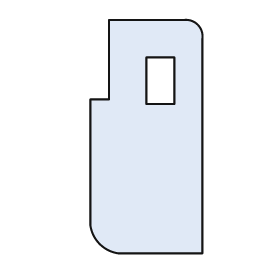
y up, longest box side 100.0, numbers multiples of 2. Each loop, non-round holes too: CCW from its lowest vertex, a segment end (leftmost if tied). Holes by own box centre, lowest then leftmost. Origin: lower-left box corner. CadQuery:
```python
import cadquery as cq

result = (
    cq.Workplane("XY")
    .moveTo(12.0, 0.0)
    .lineTo(48.0, 0.0)
    .lineTo(48.0, 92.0)
    .threePointArc((46.0, 98.0), (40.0, 100.0))
    .lineTo(8.0, 100.0)
    .lineTo(8.0, 66.0)
    .lineTo(0.0, 66.0)
    .lineTo(0.0, 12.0)
    .threePointArc((4.0, 4.0), (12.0, 0.0))
    .close()
    .moveTo(24.0, 64.0)
    .lineTo(36.0, 64.0)
    .lineTo(36.0, 84.0)
    .lineTo(24.0, 84.0)
    .close()
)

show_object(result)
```